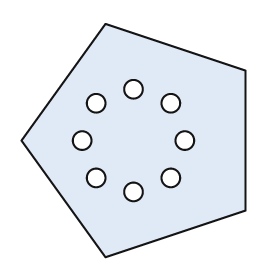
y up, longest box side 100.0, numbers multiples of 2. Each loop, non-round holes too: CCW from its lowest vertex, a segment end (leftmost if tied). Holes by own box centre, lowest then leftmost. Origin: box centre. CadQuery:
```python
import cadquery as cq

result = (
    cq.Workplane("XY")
    .moveTo(-12.0, -50.0)
    .lineTo(48.0, -30.0)
    .lineTo(48.0, 30.0)
    .lineTo(-12.0, 50.0)
    .lineTo(-48.0, 0.0)
    .close()
    .moveTo(0.0, -22.0)
    .circle(4.0)
    .moveTo(-16.0, -16.0)
    .circle(4.0)
    .moveTo(16.0, -16.0)
    .circle(4.0)
    .moveTo(-22.0, 0.0)
    .circle(4.0)
    .moveTo(22.0, 0.0)
    .circle(4.0)
    .moveTo(-16.0, 16.0)
    .circle(4.0)
    .moveTo(16.0, 16.0)
    .circle(4.0)
    .moveTo(0.0, 22.0)
    .circle(4.0)
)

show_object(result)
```